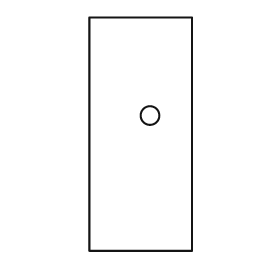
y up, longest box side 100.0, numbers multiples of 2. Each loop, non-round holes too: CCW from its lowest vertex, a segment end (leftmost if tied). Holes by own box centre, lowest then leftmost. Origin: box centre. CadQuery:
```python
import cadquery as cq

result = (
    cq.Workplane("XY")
    .moveTo(-22.0, -50.0)
    .lineTo(22.0, -50.0)
    .lineTo(22.0, 50.0)
    .lineTo(-22.0, 50.0)
    .close()
    .moveTo(4.0, 8.0)
    .circle(4.0)
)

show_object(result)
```